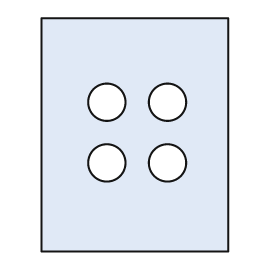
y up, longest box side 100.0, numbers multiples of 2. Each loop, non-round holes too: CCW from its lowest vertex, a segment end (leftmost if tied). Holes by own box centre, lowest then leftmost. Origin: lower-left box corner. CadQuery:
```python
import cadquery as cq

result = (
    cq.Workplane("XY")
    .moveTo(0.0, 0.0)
    .lineTo(80.0, 0.0)
    .lineTo(80.0, 100.0)
    .lineTo(0.0, 100.0)
    .close()
    .moveTo(28.0, 38.0)
    .circle(8.0)
    .moveTo(54.0, 38.0)
    .circle(8.0)
    .moveTo(28.0, 64.0)
    .circle(8.0)
    .moveTo(54.0, 64.0)
    .circle(8.0)
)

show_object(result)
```